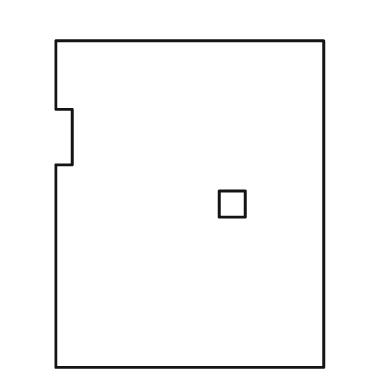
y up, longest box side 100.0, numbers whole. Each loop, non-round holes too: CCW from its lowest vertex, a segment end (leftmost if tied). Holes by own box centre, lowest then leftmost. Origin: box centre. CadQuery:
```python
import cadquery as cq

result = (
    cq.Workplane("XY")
    .moveTo(-41.0, -50.0)
    .lineTo(41.0, -50.0)
    .lineTo(41.0, 50.0)
    .lineTo(-41.0, 50.0)
    .lineTo(-41.0, 29.0)
    .lineTo(-36.0, 29.0)
    .lineTo(-36.0, 12.0)
    .lineTo(-41.0, 12.0)
    .close()
    .moveTo(9.0, -4.0)
    .lineTo(17.0, -4.0)
    .lineTo(17.0, 4.0)
    .lineTo(9.0, 4.0)
    .close()
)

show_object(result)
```